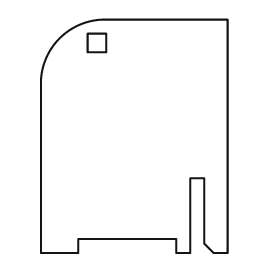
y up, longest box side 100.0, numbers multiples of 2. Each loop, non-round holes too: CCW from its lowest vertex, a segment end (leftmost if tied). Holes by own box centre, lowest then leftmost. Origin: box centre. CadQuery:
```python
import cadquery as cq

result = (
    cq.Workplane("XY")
    .moveTo(-40.0, -50.0)
    .lineTo(-24.0, -50.0)
    .lineTo(-24.0, -44.0)
    .lineTo(18.0, -44.0)
    .lineTo(18.0, -50.0)
    .lineTo(24.0, -50.0)
    .lineTo(24.0, -18.0)
    .lineTo(30.0, -18.0)
    .lineTo(30.0, -46.0)
    .lineTo(34.0, -50.0)
    .lineTo(40.0, -50.0)
    .lineTo(40.0, 50.0)
    .lineTo(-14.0, 50.0)
    .threePointArc((-32.0, 42.0), (-40.0, 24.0))
    .close()
    .moveTo(-20.0, 36.0)
    .lineTo(-12.0, 36.0)
    .lineTo(-12.0, 44.0)
    .lineTo(-20.0, 44.0)
    .close()
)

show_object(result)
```